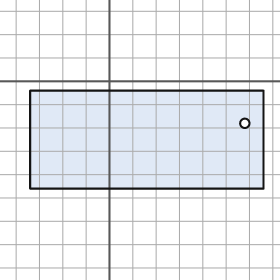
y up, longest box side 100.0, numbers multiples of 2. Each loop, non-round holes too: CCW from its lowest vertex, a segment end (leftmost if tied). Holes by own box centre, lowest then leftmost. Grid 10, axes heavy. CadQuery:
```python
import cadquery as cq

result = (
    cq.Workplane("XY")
    .moveTo(-34.0, -46.0)
    .lineTo(66.0, -46.0)
    .lineTo(66.0, -4.0)
    .lineTo(-34.0, -4.0)
    .close()
    .moveTo(58.0, -18.0)
    .circle(2.0)
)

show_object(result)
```